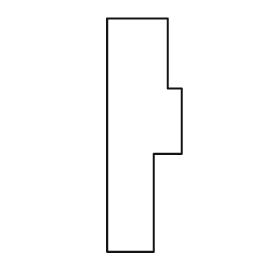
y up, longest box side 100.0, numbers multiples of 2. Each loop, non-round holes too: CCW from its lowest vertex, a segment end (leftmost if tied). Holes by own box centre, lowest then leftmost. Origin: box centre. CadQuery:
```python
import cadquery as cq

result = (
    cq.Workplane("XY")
    .moveTo(-16.0, -50.0)
    .lineTo(4.0, -50.0)
    .lineTo(4.0, -8.0)
    .lineTo(16.0, -8.0)
    .lineTo(16.0, 20.0)
    .lineTo(10.0, 20.0)
    .lineTo(10.0, 50.0)
    .lineTo(-16.0, 50.0)
    .close()
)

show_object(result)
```